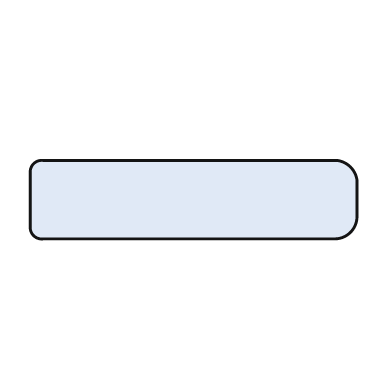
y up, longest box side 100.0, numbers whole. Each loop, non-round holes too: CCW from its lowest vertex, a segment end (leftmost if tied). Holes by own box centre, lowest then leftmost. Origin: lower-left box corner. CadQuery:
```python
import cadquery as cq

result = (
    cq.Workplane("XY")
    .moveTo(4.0, 0.0)
    .lineTo(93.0, 0.0)
    .threePointArc((98.0, 2.0), (100.0, 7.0))
    .lineTo(100.0, 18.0)
    .threePointArc((98.0, 22.0), (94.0, 24.0))
    .lineTo(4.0, 24.0)
    .threePointArc((1.0, 23.0), (0.0, 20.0))
    .lineTo(0.0, 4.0)
    .threePointArc((1.0, 1.0), (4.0, 0.0))
    .close()
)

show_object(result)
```